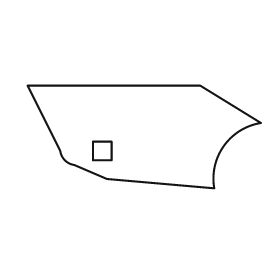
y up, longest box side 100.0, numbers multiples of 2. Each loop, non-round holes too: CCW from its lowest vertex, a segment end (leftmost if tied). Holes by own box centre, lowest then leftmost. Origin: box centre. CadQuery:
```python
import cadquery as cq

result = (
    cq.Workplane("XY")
    .moveTo(30.0, -22.0)
    .threePointArc((34.0, -4.0), (50.0, 6.0))
    .lineTo(24.0, 22.0)
    .lineTo(-50.0, 22.0)
    .lineTo(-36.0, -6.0)
    .threePointArc((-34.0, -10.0), (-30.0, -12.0))
    .lineTo(-16.0, -18.0)
    .close()
    .moveTo(-22.0, -10.0)
    .lineTo(-14.0, -10.0)
    .lineTo(-14.0, -2.0)
    .lineTo(-22.0, -2.0)
    .close()
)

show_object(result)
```